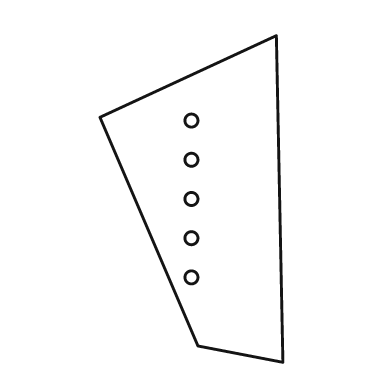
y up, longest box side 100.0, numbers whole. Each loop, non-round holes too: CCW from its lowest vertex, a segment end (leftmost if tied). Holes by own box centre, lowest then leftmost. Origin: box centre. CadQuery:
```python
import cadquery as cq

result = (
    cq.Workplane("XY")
    .moveTo(28.0, -50.0)
    .lineTo(26.0, 50.0)
    .lineTo(-28.0, 25.0)
    .lineTo(2.0, -45.0)
    .close()
    .moveTo(0.0, -24.0)
    .circle(2.0)
    .moveTo(0.0, -12.0)
    .circle(2.0)
    .moveTo(0.0, 0.0)
    .circle(2.0)
    .moveTo(0.0, 12.0)
    .circle(2.0)
    .moveTo(0.0, 24.0)
    .circle(2.0)
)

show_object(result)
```